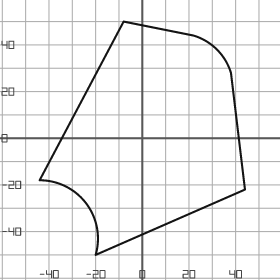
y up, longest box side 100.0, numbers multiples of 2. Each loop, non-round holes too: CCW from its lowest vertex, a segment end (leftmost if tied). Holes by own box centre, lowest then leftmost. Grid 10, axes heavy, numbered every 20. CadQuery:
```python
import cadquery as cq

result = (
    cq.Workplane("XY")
    .moveTo(-20.0, -50.0)
    .lineTo(44.0, -22.0)
    .lineTo(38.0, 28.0)
    .threePointArc((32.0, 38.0), (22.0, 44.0))
    .lineTo(-8.0, 50.0)
    .lineTo(-44.0, -18.0)
    .threePointArc((-24.0, -28.0), (-20.0, -50.0))
    .close()
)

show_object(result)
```